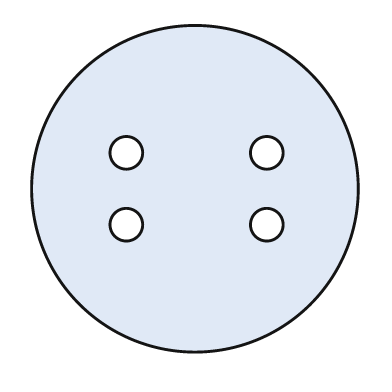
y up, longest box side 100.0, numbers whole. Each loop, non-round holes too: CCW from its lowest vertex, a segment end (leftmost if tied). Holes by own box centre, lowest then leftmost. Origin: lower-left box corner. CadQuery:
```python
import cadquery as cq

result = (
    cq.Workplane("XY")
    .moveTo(50.0, 50.0)
    .circle(50.0)
    .moveTo(29.0, 39.0)
    .circle(5.0)
    .moveTo(72.0, 39.0)
    .circle(5.0)
    .moveTo(29.0, 61.0)
    .circle(5.0)
    .moveTo(72.0, 61.0)
    .circle(5.0)
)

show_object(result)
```